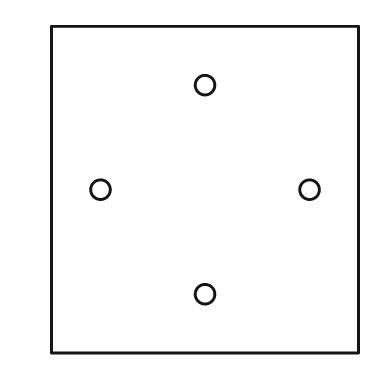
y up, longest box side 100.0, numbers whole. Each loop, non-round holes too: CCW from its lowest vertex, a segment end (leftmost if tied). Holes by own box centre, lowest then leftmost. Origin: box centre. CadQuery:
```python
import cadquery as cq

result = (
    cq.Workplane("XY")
    .moveTo(-47.0, -50.0)
    .lineTo(47.0, -50.0)
    .lineTo(47.0, 50.0)
    .lineTo(-47.0, 50.0)
    .close()
    .moveTo(0.0, -32.0)
    .circle(3.0)
    .moveTo(-32.0, 0.0)
    .circle(3.0)
    .moveTo(32.0, 0.0)
    .circle(3.0)
    .moveTo(0.0, 32.0)
    .circle(3.0)
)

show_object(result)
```